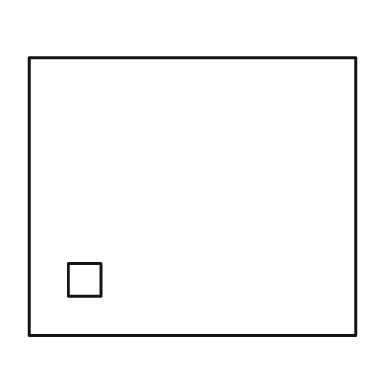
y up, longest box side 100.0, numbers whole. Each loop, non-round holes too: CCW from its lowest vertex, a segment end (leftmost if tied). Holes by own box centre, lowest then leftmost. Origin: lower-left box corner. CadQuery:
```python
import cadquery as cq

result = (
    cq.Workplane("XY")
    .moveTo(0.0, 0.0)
    .lineTo(100.0, 0.0)
    .lineTo(100.0, 85.0)
    .lineTo(0.0, 85.0)
    .close()
    .moveTo(12.0, 12.0)
    .lineTo(22.0, 12.0)
    .lineTo(22.0, 22.0)
    .lineTo(12.0, 22.0)
    .close()
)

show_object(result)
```